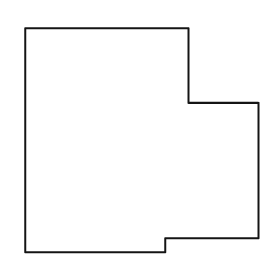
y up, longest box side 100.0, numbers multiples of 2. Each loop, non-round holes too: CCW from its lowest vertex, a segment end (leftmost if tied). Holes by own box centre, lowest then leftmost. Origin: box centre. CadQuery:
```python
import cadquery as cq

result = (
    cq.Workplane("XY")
    .moveTo(-50.0, -48.0)
    .lineTo(10.0, -48.0)
    .lineTo(10.0, -42.0)
    .lineTo(50.0, -42.0)
    .lineTo(50.0, 16.0)
    .lineTo(20.0, 16.0)
    .lineTo(20.0, 48.0)
    .lineTo(-50.0, 48.0)
    .close()
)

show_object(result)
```